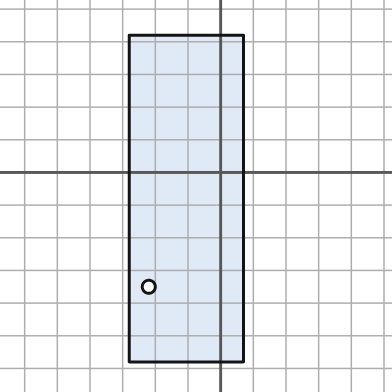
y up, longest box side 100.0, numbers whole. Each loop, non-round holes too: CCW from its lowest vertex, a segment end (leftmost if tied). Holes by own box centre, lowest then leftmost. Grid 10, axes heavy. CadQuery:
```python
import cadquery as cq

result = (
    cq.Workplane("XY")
    .moveTo(-28.0, -58.0)
    .lineTo(7.0, -58.0)
    .lineTo(7.0, 42.0)
    .lineTo(-28.0, 42.0)
    .close()
    .moveTo(-22.0, -35.0)
    .circle(2.0)
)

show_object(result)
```